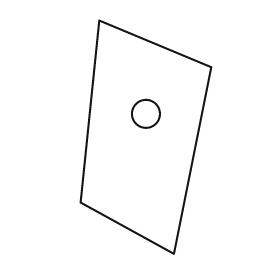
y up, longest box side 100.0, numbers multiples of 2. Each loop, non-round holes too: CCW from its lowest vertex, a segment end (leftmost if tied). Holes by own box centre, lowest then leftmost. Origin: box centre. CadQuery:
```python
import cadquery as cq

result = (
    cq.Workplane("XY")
    .moveTo(12.0, -50.0)
    .lineTo(28.0, 30.0)
    .lineTo(-20.0, 50.0)
    .lineTo(-28.0, -28.0)
    .close()
    .moveTo(0.0, 10.0)
    .circle(6.0)
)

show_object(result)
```